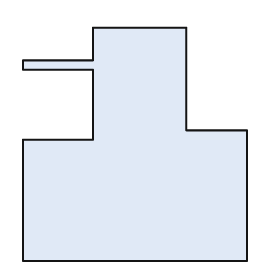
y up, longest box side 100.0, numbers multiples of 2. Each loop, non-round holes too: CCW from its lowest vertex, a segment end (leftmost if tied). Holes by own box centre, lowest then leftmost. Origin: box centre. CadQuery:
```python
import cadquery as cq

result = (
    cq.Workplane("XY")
    .moveTo(-48.0, -50.0)
    .lineTo(48.0, -50.0)
    .lineTo(48.0, 6.0)
    .lineTo(22.0, 6.0)
    .lineTo(22.0, 50.0)
    .lineTo(-18.0, 50.0)
    .lineTo(-18.0, 36.0)
    .lineTo(-48.0, 36.0)
    .lineTo(-48.0, 32.0)
    .lineTo(-18.0, 32.0)
    .lineTo(-18.0, 2.0)
    .lineTo(-48.0, 2.0)
    .close()
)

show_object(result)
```